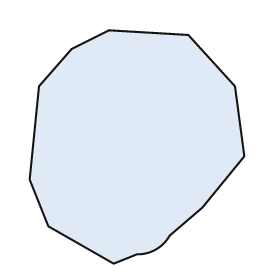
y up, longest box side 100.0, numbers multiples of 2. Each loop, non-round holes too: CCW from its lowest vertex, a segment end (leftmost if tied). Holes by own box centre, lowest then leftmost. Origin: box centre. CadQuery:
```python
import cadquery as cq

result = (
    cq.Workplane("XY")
    .moveTo(-10.0, -50.0)
    .lineTo(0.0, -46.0)
    .threePointArc((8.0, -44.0), (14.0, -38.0))
    .lineTo(28.0, -26.0)
    .lineTo(46.0, -4.0)
    .lineTo(42.0, 26.0)
    .lineTo(22.0, 48.0)
    .lineTo(-12.0, 50.0)
    .lineTo(-28.0, 42.0)
    .lineTo(-42.0, 26.0)
    .lineTo(-46.0, -14.0)
    .lineTo(-38.0, -34.0)
    .close()
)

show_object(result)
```